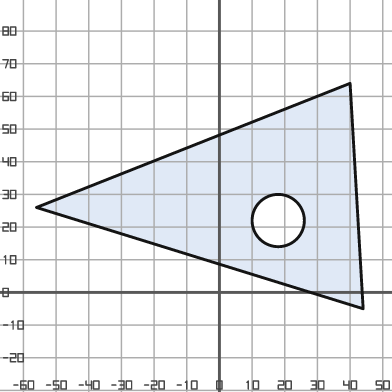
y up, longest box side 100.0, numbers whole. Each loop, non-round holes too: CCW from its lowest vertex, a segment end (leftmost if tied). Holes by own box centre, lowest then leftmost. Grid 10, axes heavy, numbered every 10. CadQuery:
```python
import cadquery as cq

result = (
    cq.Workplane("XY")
    .moveTo(44.0, -5.0)
    .lineTo(40.0, 64.0)
    .lineTo(-56.0, 26.0)
    .close()
    .moveTo(18.0, 22.0)
    .circle(8.0)
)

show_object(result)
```